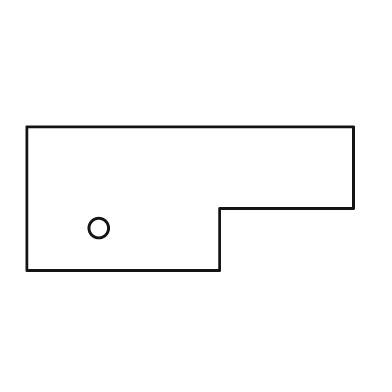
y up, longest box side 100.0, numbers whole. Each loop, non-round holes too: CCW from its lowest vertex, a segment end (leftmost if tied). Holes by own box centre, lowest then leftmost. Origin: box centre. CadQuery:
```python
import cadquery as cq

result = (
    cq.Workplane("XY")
    .moveTo(-50.0, -22.0)
    .lineTo(9.0, -22.0)
    .lineTo(9.0, -3.0)
    .lineTo(50.0, -3.0)
    .lineTo(50.0, 22.0)
    .lineTo(-50.0, 22.0)
    .close()
    .moveTo(-28.0, -9.0)
    .circle(3.0)
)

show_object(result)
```